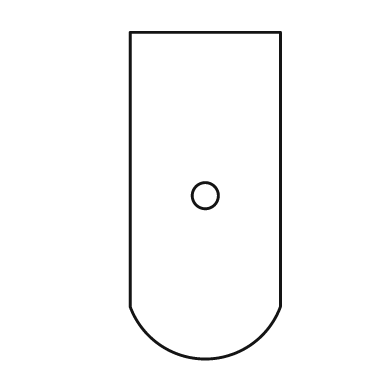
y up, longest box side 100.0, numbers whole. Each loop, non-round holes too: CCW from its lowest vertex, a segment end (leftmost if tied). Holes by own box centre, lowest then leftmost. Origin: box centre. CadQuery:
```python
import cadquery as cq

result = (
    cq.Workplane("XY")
    .moveTo(-23.0, -34.0)
    .threePointArc((0.0, -50.0), (23.0, -34.0))
    .lineTo(23.0, 50.0)
    .lineTo(-23.0, 50.0)
    .close()
    .moveTo(0.0, 0.0)
    .circle(4.0)
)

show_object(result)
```